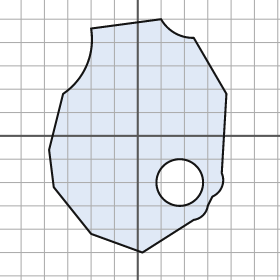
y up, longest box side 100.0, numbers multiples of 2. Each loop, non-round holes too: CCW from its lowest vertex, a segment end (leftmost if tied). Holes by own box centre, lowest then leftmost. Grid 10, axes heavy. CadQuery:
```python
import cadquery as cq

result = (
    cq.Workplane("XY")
    .moveTo(2.0, -50.0)
    .lineTo(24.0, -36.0)
    .threePointArc((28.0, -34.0), (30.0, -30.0))
    .lineTo(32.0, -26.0)
    .threePointArc((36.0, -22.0), (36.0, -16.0))
    .lineTo(38.0, 18.0)
    .lineTo(24.0, 42.0)
    .threePointArc((16.0, 44.0), (10.0, 50.0))
    .lineTo(-20.0, 46.0)
    .threePointArc((-22.0, 30.0), (-32.0, 18.0))
    .lineTo(-38.0, -6.0)
    .lineTo(-36.0, -22.0)
    .lineTo(-20.0, -42.0)
    .close()
    .moveTo(18.0, -20.0)
    .circle(10.0)
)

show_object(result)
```